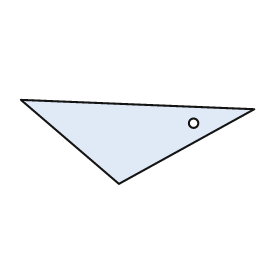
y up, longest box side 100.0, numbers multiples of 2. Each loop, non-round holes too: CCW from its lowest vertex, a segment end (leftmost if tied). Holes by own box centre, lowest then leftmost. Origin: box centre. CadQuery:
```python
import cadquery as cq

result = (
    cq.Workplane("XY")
    .moveTo(-8.0, -18.0)
    .lineTo(50.0, 14.0)
    .lineTo(-50.0, 18.0)
    .close()
    .moveTo(24.0, 8.0)
    .circle(2.0)
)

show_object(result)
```